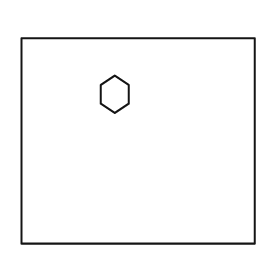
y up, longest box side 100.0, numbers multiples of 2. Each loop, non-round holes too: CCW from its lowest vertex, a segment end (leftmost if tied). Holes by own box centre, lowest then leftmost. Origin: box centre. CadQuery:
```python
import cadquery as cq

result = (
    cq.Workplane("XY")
    .moveTo(-50.0, -44.0)
    .lineTo(50.0, -44.0)
    .lineTo(50.0, 44.0)
    .lineTo(-50.0, 44.0)
    .close()
    .moveTo(-10.0, 12.0)
    .lineTo(-4.0, 16.0)
    .lineTo(-4.0, 24.0)
    .lineTo(-10.0, 28.0)
    .lineTo(-16.0, 24.0)
    .lineTo(-16.0, 16.0)
    .close()
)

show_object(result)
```